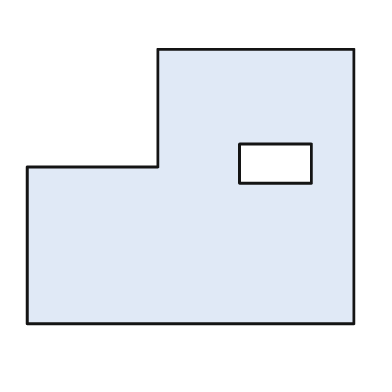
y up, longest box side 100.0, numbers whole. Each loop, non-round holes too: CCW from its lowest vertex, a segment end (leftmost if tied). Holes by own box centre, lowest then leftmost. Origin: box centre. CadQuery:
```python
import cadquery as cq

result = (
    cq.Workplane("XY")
    .moveTo(-50.0, -42.0)
    .lineTo(50.0, -42.0)
    .lineTo(50.0, 42.0)
    .lineTo(-10.0, 42.0)
    .lineTo(-10.0, 6.0)
    .lineTo(-50.0, 6.0)
    .close()
    .moveTo(15.0, 1.0)
    .lineTo(37.0, 1.0)
    .lineTo(37.0, 13.0)
    .lineTo(15.0, 13.0)
    .close()
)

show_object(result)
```